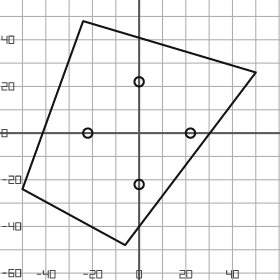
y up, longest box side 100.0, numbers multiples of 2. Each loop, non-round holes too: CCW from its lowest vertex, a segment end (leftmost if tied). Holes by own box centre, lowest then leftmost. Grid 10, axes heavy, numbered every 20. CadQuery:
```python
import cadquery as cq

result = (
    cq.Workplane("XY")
    .moveTo(-6.0, -48.0)
    .lineTo(50.0, 26.0)
    .lineTo(-24.0, 48.0)
    .lineTo(-50.0, -24.0)
    .close()
    .moveTo(0.0, -22.0)
    .circle(2.0)
    .moveTo(-22.0, 0.0)
    .circle(2.0)
    .moveTo(22.0, 0.0)
    .circle(2.0)
    .moveTo(0.0, 22.0)
    .circle(2.0)
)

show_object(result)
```